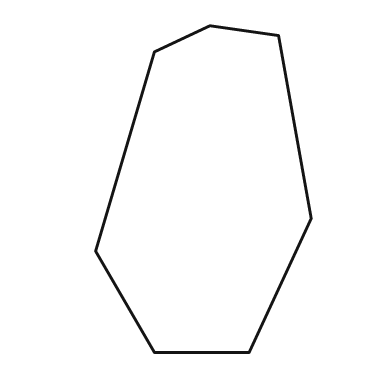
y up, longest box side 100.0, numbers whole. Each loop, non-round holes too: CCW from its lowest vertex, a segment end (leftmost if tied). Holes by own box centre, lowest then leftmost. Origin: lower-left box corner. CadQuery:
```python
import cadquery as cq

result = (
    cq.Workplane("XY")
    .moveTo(18.0, 0.0)
    .lineTo(47.0, 0.0)
    .lineTo(66.0, 41.0)
    .lineTo(56.0, 97.0)
    .lineTo(35.0, 100.0)
    .lineTo(18.0, 92.0)
    .lineTo(0.0, 31.0)
    .close()
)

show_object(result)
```